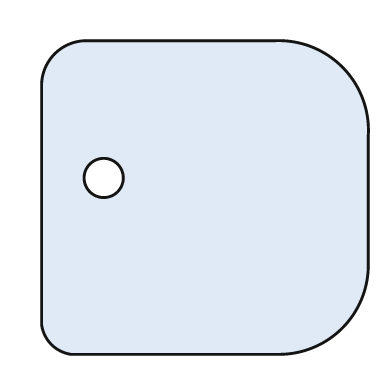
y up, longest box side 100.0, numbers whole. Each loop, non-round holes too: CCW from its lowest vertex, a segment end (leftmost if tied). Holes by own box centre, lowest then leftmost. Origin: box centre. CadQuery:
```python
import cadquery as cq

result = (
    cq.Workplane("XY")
    .moveTo(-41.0, -48.0)
    .lineTo(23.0, -48.0)
    .threePointArc((42.0, -40.0), (50.0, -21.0))
    .lineTo(50.0, 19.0)
    .threePointArc((42.0, 40.0), (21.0, 48.0))
    .lineTo(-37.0, 48.0)
    .threePointArc((-46.0, 44.0), (-50.0, 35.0))
    .lineTo(-50.0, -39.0)
    .threePointArc((-47.0, -45.0), (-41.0, -48.0))
    .close()
    .moveTo(-31.0, 6.0)
    .circle(6.0)
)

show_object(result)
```